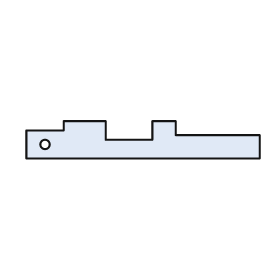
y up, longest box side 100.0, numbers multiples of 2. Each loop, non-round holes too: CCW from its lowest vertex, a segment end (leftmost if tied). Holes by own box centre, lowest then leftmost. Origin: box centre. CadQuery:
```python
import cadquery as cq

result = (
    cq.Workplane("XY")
    .moveTo(-50.0, -8.0)
    .lineTo(50.0, -8.0)
    .lineTo(50.0, 2.0)
    .lineTo(14.0, 2.0)
    .lineTo(14.0, 8.0)
    .lineTo(4.0, 8.0)
    .lineTo(4.0, 0.0)
    .lineTo(-16.0, 0.0)
    .lineTo(-16.0, 8.0)
    .lineTo(-34.0, 8.0)
    .lineTo(-34.0, 4.0)
    .lineTo(-50.0, 4.0)
    .close()
    .moveTo(-42.0, -2.0)
    .circle(2.0)
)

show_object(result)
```